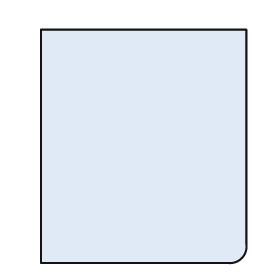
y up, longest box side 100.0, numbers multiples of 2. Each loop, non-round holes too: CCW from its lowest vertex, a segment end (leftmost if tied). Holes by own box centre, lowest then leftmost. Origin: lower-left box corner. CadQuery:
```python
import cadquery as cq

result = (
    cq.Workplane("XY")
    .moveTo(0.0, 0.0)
    .lineTo(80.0, 0.0)
    .threePointArc((86.0, 2.0), (88.0, 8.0))
    .lineTo(88.0, 100.0)
    .lineTo(0.0, 100.0)
    .close()
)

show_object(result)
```